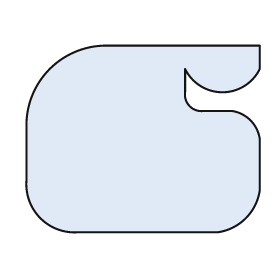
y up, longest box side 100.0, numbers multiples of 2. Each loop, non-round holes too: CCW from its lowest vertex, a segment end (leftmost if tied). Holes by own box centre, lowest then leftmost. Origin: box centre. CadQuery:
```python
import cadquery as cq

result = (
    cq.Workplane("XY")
    .moveTo(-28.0, -40.0)
    .lineTo(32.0, -40.0)
    .threePointArc((44.0, -34.0), (50.0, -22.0))
    .lineTo(50.0, 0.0)
    .threePointArc((46.0, 8.0), (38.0, 12.0))
    .lineTo(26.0, 12.0)
    .threePointArc((20.0, 14.0), (18.0, 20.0))
    .lineTo(18.0, 30.0)
    .threePointArc((34.0, 20.0), (50.0, 30.0))
    .lineTo(50.0, 40.0)
    .lineTo(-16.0, 40.0)
    .threePointArc((-40.0, 30.0), (-50.0, 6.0))
    .lineTo(-50.0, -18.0)
    .threePointArc((-44.0, -34.0), (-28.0, -40.0))
    .close()
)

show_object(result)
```